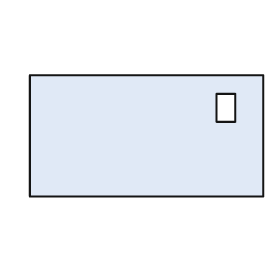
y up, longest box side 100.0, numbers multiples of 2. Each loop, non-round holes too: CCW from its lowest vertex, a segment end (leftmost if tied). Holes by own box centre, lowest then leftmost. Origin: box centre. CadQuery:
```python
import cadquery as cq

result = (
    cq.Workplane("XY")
    .moveTo(-50.0, -26.0)
    .lineTo(50.0, -26.0)
    .lineTo(50.0, 26.0)
    .lineTo(-50.0, 26.0)
    .close()
    .moveTo(30.0, 6.0)
    .lineTo(38.0, 6.0)
    .lineTo(38.0, 18.0)
    .lineTo(30.0, 18.0)
    .close()
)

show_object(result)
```